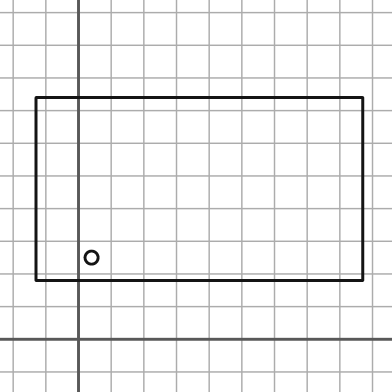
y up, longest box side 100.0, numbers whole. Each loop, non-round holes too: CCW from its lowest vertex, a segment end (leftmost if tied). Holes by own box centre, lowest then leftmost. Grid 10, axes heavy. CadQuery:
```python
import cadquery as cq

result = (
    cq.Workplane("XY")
    .moveTo(-13.0, 18.0)
    .lineTo(87.0, 18.0)
    .lineTo(87.0, 74.0)
    .lineTo(-13.0, 74.0)
    .close()
    .moveTo(4.0, 25.0)
    .circle(2.0)
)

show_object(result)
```